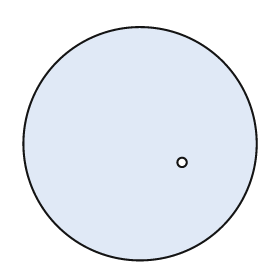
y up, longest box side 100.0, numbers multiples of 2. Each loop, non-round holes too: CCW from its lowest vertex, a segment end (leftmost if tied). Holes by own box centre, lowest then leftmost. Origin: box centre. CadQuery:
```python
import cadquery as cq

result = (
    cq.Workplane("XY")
    .moveTo(0.0, 0.0)
    .circle(50.0)
    .moveTo(18.0, -8.0)
    .circle(2.0)
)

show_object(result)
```